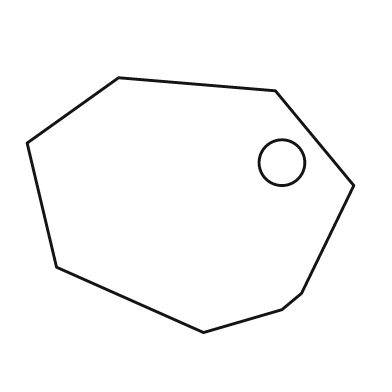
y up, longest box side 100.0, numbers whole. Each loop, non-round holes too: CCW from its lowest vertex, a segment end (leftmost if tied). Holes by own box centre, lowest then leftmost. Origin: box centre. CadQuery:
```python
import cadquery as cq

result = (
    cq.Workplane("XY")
    .moveTo(4.0, -39.0)
    .lineTo(28.0, -32.0)
    .lineTo(34.0, -27.0)
    .lineTo(50.0, 6.0)
    .lineTo(26.0, 35.0)
    .lineTo(-22.0, 39.0)
    .lineTo(-50.0, 19.0)
    .lineTo(-41.0, -19.0)
    .close()
    .moveTo(28.0, 13.0)
    .circle(7.0)
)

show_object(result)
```